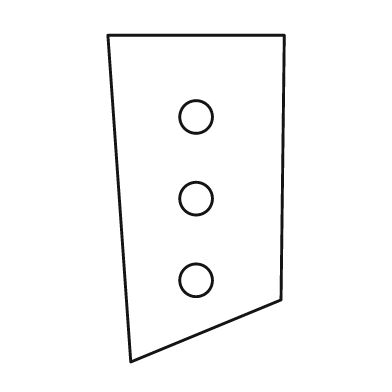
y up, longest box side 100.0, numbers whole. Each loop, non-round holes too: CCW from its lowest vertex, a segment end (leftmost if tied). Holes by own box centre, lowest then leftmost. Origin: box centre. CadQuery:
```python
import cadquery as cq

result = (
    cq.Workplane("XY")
    .moveTo(-20.0, -50.0)
    .lineTo(26.0, -31.0)
    .lineTo(27.0, 50.0)
    .lineTo(-27.0, 50.0)
    .close()
    .moveTo(0.0, -25.0)
    .circle(5.0)
    .moveTo(0.0, 0.0)
    .circle(5.0)
    .moveTo(0.0, 25.0)
    .circle(5.0)
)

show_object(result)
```